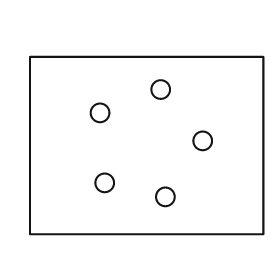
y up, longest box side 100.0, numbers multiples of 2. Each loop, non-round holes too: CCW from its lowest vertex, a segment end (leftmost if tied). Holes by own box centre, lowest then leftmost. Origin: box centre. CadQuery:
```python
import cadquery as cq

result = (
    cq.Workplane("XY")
    .moveTo(-50.0, -38.0)
    .lineTo(50.0, -38.0)
    .lineTo(50.0, 38.0)
    .lineTo(-50.0, 38.0)
    .close()
    .moveTo(8.0, -22.0)
    .circle(4.0)
    .moveTo(-18.0, -16.0)
    .circle(4.0)
    .moveTo(24.0, 2.0)
    .circle(4.0)
    .moveTo(-20.0, 14.0)
    .circle(4.0)
    .moveTo(6.0, 24.0)
    .circle(4.0)
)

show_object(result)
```